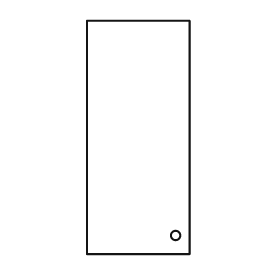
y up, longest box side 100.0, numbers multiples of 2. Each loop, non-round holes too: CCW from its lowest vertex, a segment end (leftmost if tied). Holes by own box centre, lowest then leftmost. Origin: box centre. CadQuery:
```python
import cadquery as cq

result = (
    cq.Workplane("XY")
    .moveTo(-22.0, -50.0)
    .lineTo(22.0, -50.0)
    .lineTo(22.0, 50.0)
    .lineTo(-22.0, 50.0)
    .close()
    .moveTo(16.0, -42.0)
    .circle(2.0)
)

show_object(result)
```